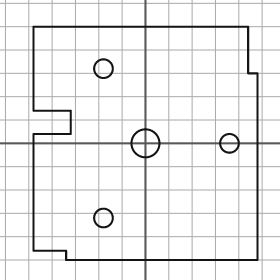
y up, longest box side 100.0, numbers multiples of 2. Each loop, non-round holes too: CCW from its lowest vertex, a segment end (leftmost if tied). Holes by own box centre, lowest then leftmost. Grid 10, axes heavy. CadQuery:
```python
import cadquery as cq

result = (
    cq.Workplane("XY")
    .moveTo(-34.0, -50.0)
    .lineTo(48.0, -50.0)
    .lineTo(48.0, 30.0)
    .lineTo(44.0, 30.0)
    .lineTo(44.0, 50.0)
    .lineTo(-48.0, 50.0)
    .lineTo(-48.0, 14.0)
    .lineTo(-32.0, 14.0)
    .lineTo(-32.0, 4.0)
    .lineTo(-48.0, 4.0)
    .lineTo(-48.0, -46.0)
    .lineTo(-34.0, -46.0)
    .close()
    .moveTo(-18.0, -32.0)
    .circle(4.0)
    .moveTo(0.0, 0.0)
    .circle(6.0)
    .moveTo(36.0, 0.0)
    .circle(4.0)
    .moveTo(-18.0, 32.0)
    .circle(4.0)
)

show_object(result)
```